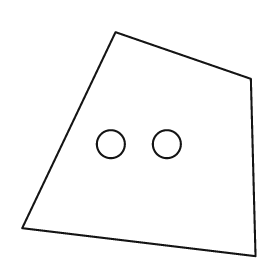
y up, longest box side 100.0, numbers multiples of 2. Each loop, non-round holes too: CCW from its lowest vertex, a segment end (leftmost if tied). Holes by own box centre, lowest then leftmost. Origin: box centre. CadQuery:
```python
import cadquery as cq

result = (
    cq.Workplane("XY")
    .moveTo(50.0, -48.0)
    .lineTo(48.0, 28.0)
    .lineTo(-10.0, 48.0)
    .lineTo(-50.0, -36.0)
    .close()
    .moveTo(-12.0, 0.0)
    .circle(6.0)
    .moveTo(12.0, 0.0)
    .circle(6.0)
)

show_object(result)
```